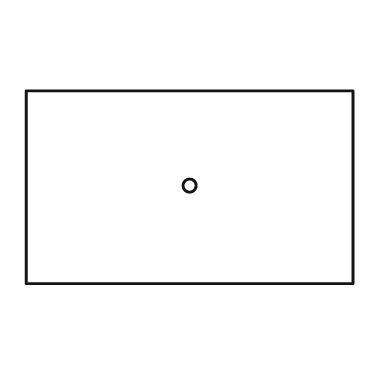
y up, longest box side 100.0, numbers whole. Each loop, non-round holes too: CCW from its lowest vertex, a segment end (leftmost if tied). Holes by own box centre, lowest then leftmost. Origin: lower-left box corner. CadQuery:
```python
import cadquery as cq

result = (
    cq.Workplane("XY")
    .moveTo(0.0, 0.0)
    .lineTo(100.0, 0.0)
    .lineTo(100.0, 59.0)
    .lineTo(0.0, 59.0)
    .close()
    .moveTo(50.0, 30.0)
    .circle(2.0)
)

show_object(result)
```